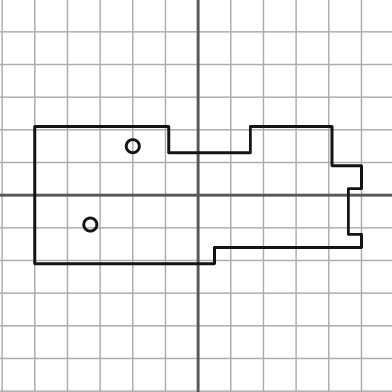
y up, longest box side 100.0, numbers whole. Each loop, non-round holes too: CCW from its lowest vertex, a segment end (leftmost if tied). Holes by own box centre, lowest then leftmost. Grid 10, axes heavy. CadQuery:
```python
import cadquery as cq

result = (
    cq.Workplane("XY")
    .moveTo(-50.0, -21.0)
    .lineTo(5.0, -21.0)
    .lineTo(5.0, -16.0)
    .lineTo(50.0, -16.0)
    .lineTo(50.0, -12.0)
    .lineTo(46.0, -12.0)
    .lineTo(46.0, 2.0)
    .lineTo(50.0, 2.0)
    .lineTo(50.0, 9.0)
    .lineTo(41.0, 9.0)
    .lineTo(41.0, 21.0)
    .lineTo(16.0, 21.0)
    .lineTo(16.0, 13.0)
    .lineTo(-9.0, 13.0)
    .lineTo(-9.0, 21.0)
    .lineTo(-50.0, 21.0)
    .close()
    .moveTo(-33.0, -9.0)
    .circle(2.0)
    .moveTo(-20.0, 15.0)
    .circle(2.0)
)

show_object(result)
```